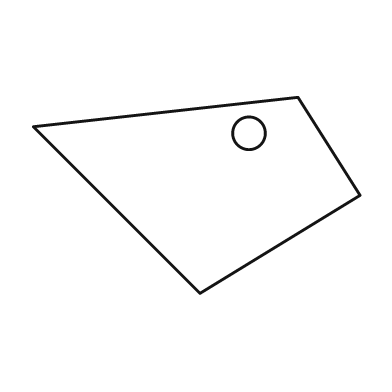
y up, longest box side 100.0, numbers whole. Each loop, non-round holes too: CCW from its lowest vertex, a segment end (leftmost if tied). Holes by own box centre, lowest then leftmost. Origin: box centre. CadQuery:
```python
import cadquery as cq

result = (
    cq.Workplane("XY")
    .moveTo(1.0, -30.0)
    .lineTo(50.0, 0.0)
    .lineTo(31.0, 30.0)
    .lineTo(-50.0, 21.0)
    .close()
    .moveTo(16.0, 19.0)
    .circle(5.0)
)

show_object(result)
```